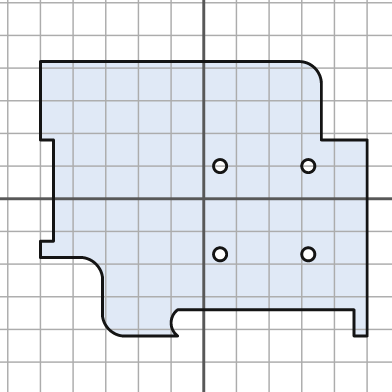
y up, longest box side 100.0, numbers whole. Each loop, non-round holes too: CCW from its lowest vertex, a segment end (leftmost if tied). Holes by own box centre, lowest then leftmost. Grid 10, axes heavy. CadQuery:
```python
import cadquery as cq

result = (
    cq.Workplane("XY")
    .moveTo(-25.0, -42.0)
    .lineTo(-8.0, -42.0)
    .threePointArc((-10.0, -38.0), (-8.0, -34.0))
    .lineTo(46.0, -34.0)
    .lineTo(46.0, -42.0)
    .lineTo(50.0, -42.0)
    .lineTo(50.0, 18.0)
    .lineTo(36.0, 18.0)
    .lineTo(36.0, 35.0)
    .threePointArc((34.0, 40.0), (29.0, 42.0))
    .lineTo(-50.0, 42.0)
    .lineTo(-50.0, 18.0)
    .lineTo(-46.0, 18.0)
    .lineTo(-46.0, -13.0)
    .lineTo(-50.0, -13.0)
    .lineTo(-50.0, -18.0)
    .lineTo(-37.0, -18.0)
    .threePointArc((-33.0, -20.0), (-31.0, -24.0))
    .lineTo(-31.0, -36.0)
    .threePointArc((-29.0, -40.0), (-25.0, -42.0))
    .close()
    .moveTo(5.0, -17.0)
    .circle(2.0)
    .moveTo(32.0, -17.0)
    .circle(2.0)
    .moveTo(5.0, 10.0)
    .circle(2.0)
    .moveTo(32.0, 10.0)
    .circle(2.0)
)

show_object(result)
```